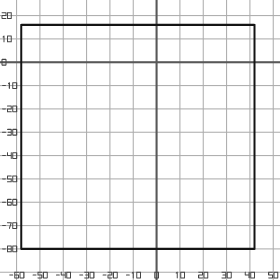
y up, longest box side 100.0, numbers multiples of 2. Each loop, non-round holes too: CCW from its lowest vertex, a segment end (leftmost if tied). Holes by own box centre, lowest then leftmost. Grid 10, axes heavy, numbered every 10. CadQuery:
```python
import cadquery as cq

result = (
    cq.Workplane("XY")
    .moveTo(-58.0, -80.0)
    .lineTo(42.0, -80.0)
    .lineTo(42.0, 16.0)
    .lineTo(-58.0, 16.0)
    .close()
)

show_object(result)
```